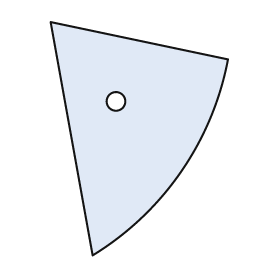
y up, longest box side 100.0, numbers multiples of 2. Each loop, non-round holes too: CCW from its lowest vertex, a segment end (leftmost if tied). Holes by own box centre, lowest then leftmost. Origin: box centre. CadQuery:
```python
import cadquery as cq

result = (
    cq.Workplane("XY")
    .moveTo(-20.0, -50.0)
    .threePointArc((18.0, -14.0), (38.0, 34.0))
    .lineTo(-38.0, 50.0)
    .close()
    .moveTo(-10.0, 16.0)
    .circle(4.0)
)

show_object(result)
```